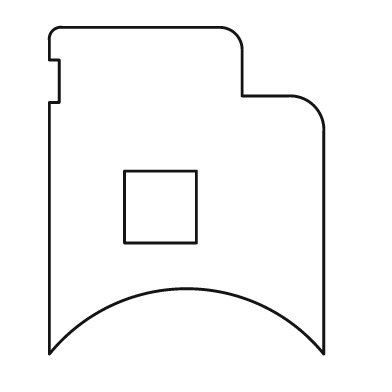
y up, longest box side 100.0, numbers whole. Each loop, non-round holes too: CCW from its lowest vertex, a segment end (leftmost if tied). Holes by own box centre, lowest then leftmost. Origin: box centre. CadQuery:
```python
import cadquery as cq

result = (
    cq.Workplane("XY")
    .moveTo(-42.0, -50.0)
    .threePointArc((0.0, -30.0), (42.0, -50.0))
    .lineTo(42.0, 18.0)
    .threePointArc((39.0, 26.0), (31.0, 29.0))
    .lineTo(17.0, 29.0)
    .lineTo(17.0, 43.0)
    .threePointArc((15.0, 48.0), (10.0, 50.0))
    .lineTo(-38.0, 50.0)
    .threePointArc((-41.0, 49.0), (-42.0, 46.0))
    .lineTo(-42.0, 40.0)
    .lineTo(-39.0, 40.0)
    .lineTo(-39.0, 27.0)
    .lineTo(-42.0, 27.0)
    .close()
    .moveTo(-19.0, -16.0)
    .lineTo(3.0, -16.0)
    .lineTo(3.0, 6.0)
    .lineTo(-19.0, 6.0)
    .close()
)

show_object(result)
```